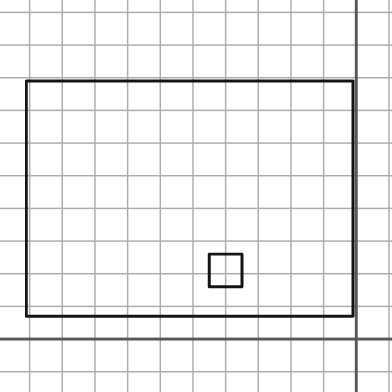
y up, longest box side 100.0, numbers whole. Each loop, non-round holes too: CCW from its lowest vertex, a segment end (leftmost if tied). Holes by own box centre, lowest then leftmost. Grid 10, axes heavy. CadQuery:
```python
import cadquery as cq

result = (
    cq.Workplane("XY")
    .moveTo(-101.0, 7.0)
    .lineTo(-1.0, 7.0)
    .lineTo(-1.0, 79.0)
    .lineTo(-101.0, 79.0)
    .close()
    .moveTo(-45.0, 16.0)
    .lineTo(-35.0, 16.0)
    .lineTo(-35.0, 26.0)
    .lineTo(-45.0, 26.0)
    .close()
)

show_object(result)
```